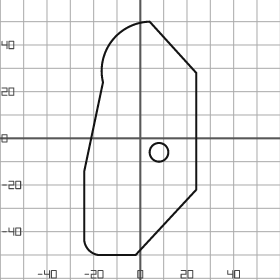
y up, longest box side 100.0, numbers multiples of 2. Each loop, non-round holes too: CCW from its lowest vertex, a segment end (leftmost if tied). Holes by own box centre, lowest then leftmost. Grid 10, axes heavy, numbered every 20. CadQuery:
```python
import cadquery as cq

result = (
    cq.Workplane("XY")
    .moveTo(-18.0, -50.0)
    .lineTo(-2.0, -50.0)
    .lineTo(24.0, -22.0)
    .lineTo(24.0, 28.0)
    .lineTo(4.0, 50.0)
    .threePointArc((-12.0, 42.0), (-16.0, 24.0))
    .lineTo(-24.0, -14.0)
    .lineTo(-24.0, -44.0)
    .threePointArc((-22.0, -48.0), (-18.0, -50.0))
    .close()
    .moveTo(8.0, -6.0)
    .circle(4.0)
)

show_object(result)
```